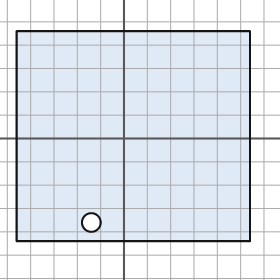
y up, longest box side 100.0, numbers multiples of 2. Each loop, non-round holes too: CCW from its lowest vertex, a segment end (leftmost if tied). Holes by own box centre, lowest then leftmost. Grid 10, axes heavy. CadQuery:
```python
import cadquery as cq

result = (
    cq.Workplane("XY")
    .moveTo(-46.0, -44.0)
    .lineTo(54.0, -44.0)
    .lineTo(54.0, 46.0)
    .lineTo(-46.0, 46.0)
    .close()
    .moveTo(-14.0, -36.0)
    .circle(4.0)
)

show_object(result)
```